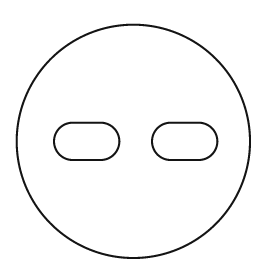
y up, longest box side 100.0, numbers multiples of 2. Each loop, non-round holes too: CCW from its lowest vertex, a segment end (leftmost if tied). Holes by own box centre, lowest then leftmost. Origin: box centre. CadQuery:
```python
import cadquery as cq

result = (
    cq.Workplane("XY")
    .moveTo(0.0, 0.0)
    .circle(50.0)
    .moveTo(-26.0, -8.0)
    .lineTo(-14.0, -8.0)
    .threePointArc((-6.0, 0.0), (-14.0, 8.0))
    .lineTo(-26.0, 8.0)
    .threePointArc((-34.0, 0.0), (-26.0, -8.0))
    .close()
    .moveTo(16.0, -8.0)
    .lineTo(28.0, -8.0)
    .threePointArc((36.0, 0.0), (28.0, 8.0))
    .lineTo(16.0, 8.0)
    .threePointArc((8.0, 0.0), (16.0, -8.0))
    .close()
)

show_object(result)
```